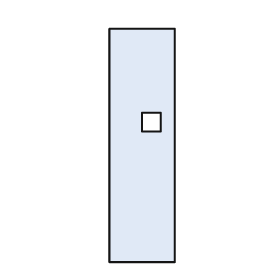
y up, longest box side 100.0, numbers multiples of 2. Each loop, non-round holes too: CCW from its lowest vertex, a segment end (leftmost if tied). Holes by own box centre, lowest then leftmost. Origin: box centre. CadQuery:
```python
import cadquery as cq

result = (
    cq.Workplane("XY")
    .moveTo(-14.0, -50.0)
    .lineTo(14.0, -50.0)
    .lineTo(14.0, 50.0)
    .lineTo(-14.0, 50.0)
    .close()
    .moveTo(0.0, 6.0)
    .lineTo(8.0, 6.0)
    .lineTo(8.0, 14.0)
    .lineTo(0.0, 14.0)
    .close()
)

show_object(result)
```